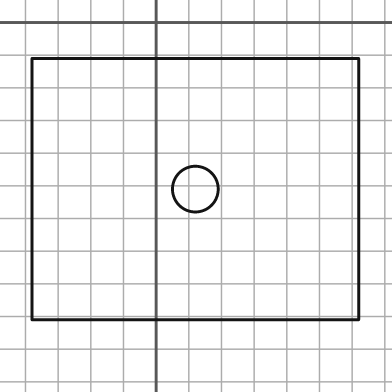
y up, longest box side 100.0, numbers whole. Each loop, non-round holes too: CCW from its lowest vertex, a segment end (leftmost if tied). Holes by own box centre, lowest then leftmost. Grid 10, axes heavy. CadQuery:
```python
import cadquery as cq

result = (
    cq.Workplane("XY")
    .moveTo(-38.0, -91.0)
    .lineTo(62.0, -91.0)
    .lineTo(62.0, -11.0)
    .lineTo(-38.0, -11.0)
    .close()
    .moveTo(12.0, -51.0)
    .circle(7.0)
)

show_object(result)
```